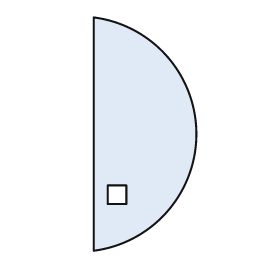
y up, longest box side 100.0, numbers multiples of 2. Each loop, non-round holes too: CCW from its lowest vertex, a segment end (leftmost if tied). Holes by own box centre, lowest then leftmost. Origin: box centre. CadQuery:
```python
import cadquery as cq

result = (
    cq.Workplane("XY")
    .moveTo(-22.0, -50.0)
    .threePointArc((22.0, 0.0), (-22.0, 50.0))
    .close()
    .moveTo(-16.0, -30.0)
    .lineTo(-8.0, -30.0)
    .lineTo(-8.0, -22.0)
    .lineTo(-16.0, -22.0)
    .close()
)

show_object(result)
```